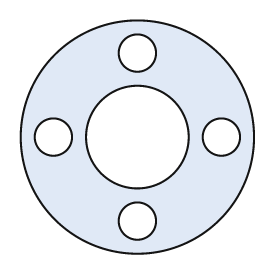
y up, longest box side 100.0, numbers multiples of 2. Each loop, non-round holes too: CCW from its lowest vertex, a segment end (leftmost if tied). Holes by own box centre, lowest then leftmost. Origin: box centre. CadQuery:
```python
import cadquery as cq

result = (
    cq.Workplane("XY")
    .moveTo(0.0, 0.0)
    .circle(50.0)
    .moveTo(0.0, -36.0)
    .circle(8.0)
    .moveTo(-36.0, 0.0)
    .circle(8.0)
    .moveTo(0.0, 0.0)
    .circle(22.0)
    .moveTo(36.0, 0.0)
    .circle(8.0)
    .moveTo(0.0, 36.0)
    .circle(8.0)
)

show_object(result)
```